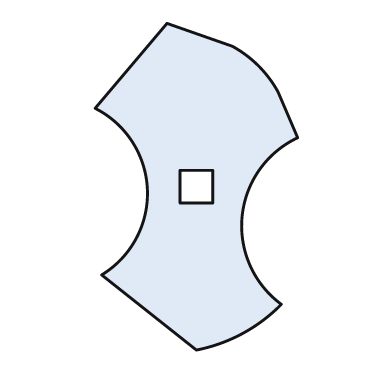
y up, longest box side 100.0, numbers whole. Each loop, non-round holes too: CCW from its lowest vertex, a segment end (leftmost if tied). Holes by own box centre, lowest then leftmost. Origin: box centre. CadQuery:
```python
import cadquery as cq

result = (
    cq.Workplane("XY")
    .moveTo(0.0, -50.0)
    .threePointArc((14.0, -45.0), (26.0, -36.0))
    .threePointArc((14.0, -9.0), (31.0, 15.0))
    .lineTo(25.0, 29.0)
    .threePointArc((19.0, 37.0), (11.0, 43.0))
    .lineTo(-9.0, 50.0)
    .lineTo(-31.0, 24.0)
    .threePointArc((-15.0, -1.0), (-29.0, -27.0))
    .close()
    .moveTo(-5.0, -5.0)
    .lineTo(5.0, -5.0)
    .lineTo(5.0, 5.0)
    .lineTo(-5.0, 5.0)
    .close()
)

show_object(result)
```